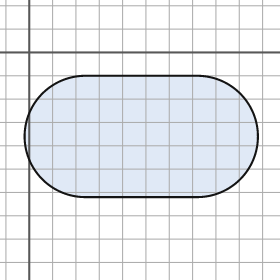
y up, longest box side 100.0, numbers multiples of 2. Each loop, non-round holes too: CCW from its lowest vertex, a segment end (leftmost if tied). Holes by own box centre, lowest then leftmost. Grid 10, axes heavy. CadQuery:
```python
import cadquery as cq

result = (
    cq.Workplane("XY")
    .moveTo(24.0, -62.0)
    .lineTo(72.0, -62.0)
    .threePointArc((98.0, -36.0), (72.0, -10.0))
    .lineTo(24.0, -10.0)
    .threePointArc((-2.0, -36.0), (24.0, -62.0))
    .close()
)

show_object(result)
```